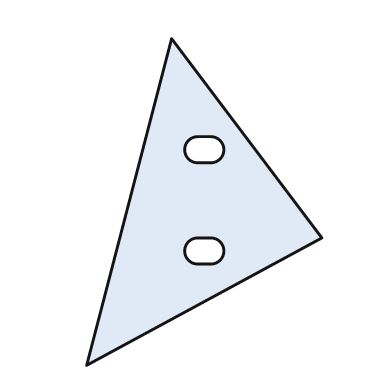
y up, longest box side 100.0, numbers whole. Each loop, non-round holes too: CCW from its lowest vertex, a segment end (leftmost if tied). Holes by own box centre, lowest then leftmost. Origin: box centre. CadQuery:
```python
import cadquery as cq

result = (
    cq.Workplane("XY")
    .moveTo(-36.0, -50.0)
    .lineTo(36.0, -11.0)
    .lineTo(-10.0, 50.0)
    .close()
    .moveTo(-2.0, -19.0)
    .lineTo(2.0, -19.0)
    .threePointArc((6.0, -15.0), (2.0, -11.0))
    .lineTo(-2.0, -11.0)
    .threePointArc((-6.0, -15.0), (-2.0, -19.0))
    .close()
    .moveTo(-2.0, 12.0)
    .lineTo(2.0, 12.0)
    .threePointArc((6.0, 16.0), (2.0, 20.0))
    .lineTo(-2.0, 20.0)
    .threePointArc((-6.0, 16.0), (-2.0, 12.0))
    .close()
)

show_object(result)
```